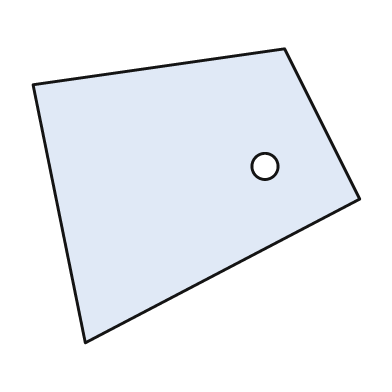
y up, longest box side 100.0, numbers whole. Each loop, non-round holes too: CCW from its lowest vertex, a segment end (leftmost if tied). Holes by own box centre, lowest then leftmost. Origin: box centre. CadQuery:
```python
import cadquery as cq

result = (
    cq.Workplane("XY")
    .moveTo(-34.0, -45.0)
    .lineTo(50.0, -1.0)
    .lineTo(27.0, 45.0)
    .lineTo(-50.0, 34.0)
    .close()
    .moveTo(21.0, 9.0)
    .circle(4.0)
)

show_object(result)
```